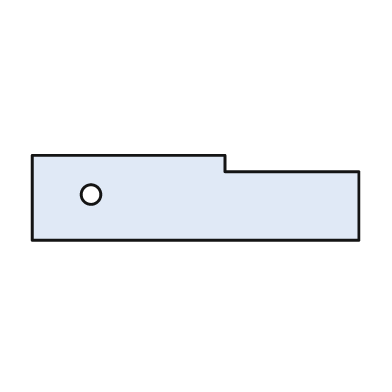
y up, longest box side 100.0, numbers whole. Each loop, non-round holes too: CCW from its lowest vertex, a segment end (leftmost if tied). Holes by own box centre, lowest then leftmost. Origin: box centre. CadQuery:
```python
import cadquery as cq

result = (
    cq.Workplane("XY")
    .moveTo(-50.0, -13.0)
    .lineTo(50.0, -13.0)
    .lineTo(50.0, 8.0)
    .lineTo(9.0, 8.0)
    .lineTo(9.0, 13.0)
    .lineTo(-50.0, 13.0)
    .close()
    .moveTo(-32.0, 1.0)
    .circle(3.0)
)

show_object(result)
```